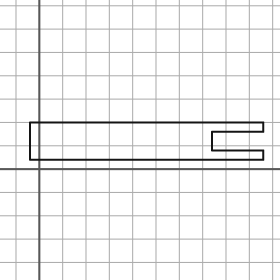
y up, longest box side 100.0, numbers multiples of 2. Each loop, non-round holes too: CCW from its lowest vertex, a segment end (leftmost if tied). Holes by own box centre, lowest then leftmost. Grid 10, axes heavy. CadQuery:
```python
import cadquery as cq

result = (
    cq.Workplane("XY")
    .moveTo(-4.0, 4.0)
    .lineTo(96.0, 4.0)
    .lineTo(96.0, 8.0)
    .lineTo(74.0, 8.0)
    .lineTo(74.0, 16.0)
    .lineTo(96.0, 16.0)
    .lineTo(96.0, 20.0)
    .lineTo(-4.0, 20.0)
    .close()
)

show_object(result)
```